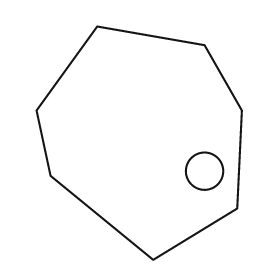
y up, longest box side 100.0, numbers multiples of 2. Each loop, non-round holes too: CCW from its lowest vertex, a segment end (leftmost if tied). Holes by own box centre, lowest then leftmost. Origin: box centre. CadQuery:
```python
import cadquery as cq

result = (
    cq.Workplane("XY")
    .moveTo(6.0, -50.0)
    .lineTo(42.0, -28.0)
    .lineTo(44.0, 14.0)
    .lineTo(28.0, 42.0)
    .lineTo(-18.0, 50.0)
    .lineTo(-44.0, 14.0)
    .lineTo(-38.0, -14.0)
    .close()
    .moveTo(28.0, -12.0)
    .circle(8.0)
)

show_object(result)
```